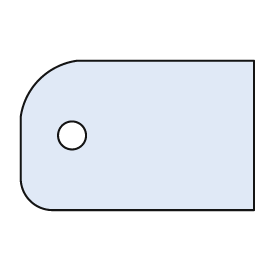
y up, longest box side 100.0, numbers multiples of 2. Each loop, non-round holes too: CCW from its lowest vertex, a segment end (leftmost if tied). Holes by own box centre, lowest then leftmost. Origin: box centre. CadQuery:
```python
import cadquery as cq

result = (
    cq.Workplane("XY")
    .moveTo(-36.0, -32.0)
    .lineTo(50.0, -32.0)
    .lineTo(50.0, 32.0)
    .lineTo(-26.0, 32.0)
    .threePointArc((-42.0, 24.0), (-50.0, 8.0))
    .lineTo(-50.0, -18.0)
    .threePointArc((-46.0, -28.0), (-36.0, -32.0))
    .close()
    .moveTo(-28.0, 0.0)
    .circle(6.0)
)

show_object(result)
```